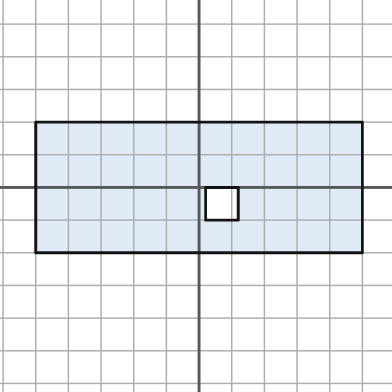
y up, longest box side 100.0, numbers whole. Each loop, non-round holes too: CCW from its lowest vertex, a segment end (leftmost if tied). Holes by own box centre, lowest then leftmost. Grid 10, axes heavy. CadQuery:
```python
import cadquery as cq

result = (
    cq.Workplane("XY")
    .moveTo(-50.0, -20.0)
    .lineTo(50.0, -20.0)
    .lineTo(50.0, 20.0)
    .lineTo(-50.0, 20.0)
    .close()
    .moveTo(2.0, -10.0)
    .lineTo(12.0, -10.0)
    .lineTo(12.0, 0.0)
    .lineTo(2.0, 0.0)
    .close()
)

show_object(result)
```